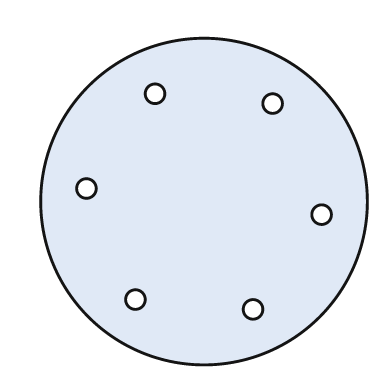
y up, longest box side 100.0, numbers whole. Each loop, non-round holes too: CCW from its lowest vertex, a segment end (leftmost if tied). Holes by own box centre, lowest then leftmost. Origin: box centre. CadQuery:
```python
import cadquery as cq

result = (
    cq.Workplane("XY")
    .moveTo(0.0, 0.0)
    .circle(50.0)
    .moveTo(15.0, -33.0)
    .circle(3.0)
    .moveTo(-21.0, -30.0)
    .circle(3.0)
    .moveTo(36.0, -4.0)
    .circle(3.0)
    .moveTo(-36.0, 4.0)
    .circle(3.0)
    .moveTo(21.0, 30.0)
    .circle(3.0)
    .moveTo(-15.0, 33.0)
    .circle(3.0)
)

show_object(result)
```